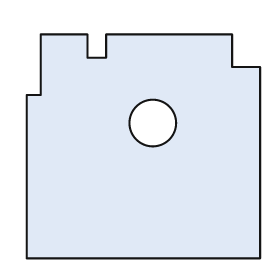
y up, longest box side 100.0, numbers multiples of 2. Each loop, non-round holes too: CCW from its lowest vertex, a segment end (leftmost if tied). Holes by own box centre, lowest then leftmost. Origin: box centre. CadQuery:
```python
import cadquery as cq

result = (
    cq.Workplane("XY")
    .moveTo(-50.0, -48.0)
    .lineTo(50.0, -48.0)
    .lineTo(50.0, 34.0)
    .lineTo(38.0, 34.0)
    .lineTo(38.0, 48.0)
    .lineTo(-16.0, 48.0)
    .lineTo(-16.0, 38.0)
    .lineTo(-24.0, 38.0)
    .lineTo(-24.0, 48.0)
    .lineTo(-44.0, 48.0)
    .lineTo(-44.0, 22.0)
    .lineTo(-50.0, 22.0)
    .close()
    .moveTo(4.0, 10.0)
    .circle(10.0)
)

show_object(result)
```